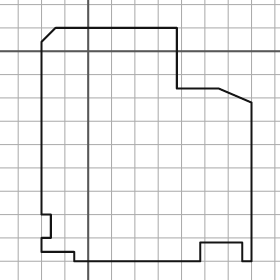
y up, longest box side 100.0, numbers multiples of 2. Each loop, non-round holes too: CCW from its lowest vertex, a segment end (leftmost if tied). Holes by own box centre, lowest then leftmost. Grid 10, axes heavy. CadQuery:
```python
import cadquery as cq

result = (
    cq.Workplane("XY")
    .moveTo(-6.0, -90.0)
    .lineTo(48.0, -90.0)
    .lineTo(48.0, -82.0)
    .lineTo(66.0, -82.0)
    .lineTo(66.0, -90.0)
    .lineTo(70.0, -90.0)
    .lineTo(70.0, -22.0)
    .lineTo(56.0, -16.0)
    .lineTo(38.0, -16.0)
    .lineTo(38.0, 10.0)
    .lineTo(-14.0, 10.0)
    .lineTo(-20.0, 4.0)
    .lineTo(-20.0, -70.0)
    .lineTo(-16.0, -70.0)
    .lineTo(-16.0, -80.0)
    .lineTo(-20.0, -80.0)
    .lineTo(-20.0, -86.0)
    .lineTo(-6.0, -86.0)
    .close()
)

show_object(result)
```